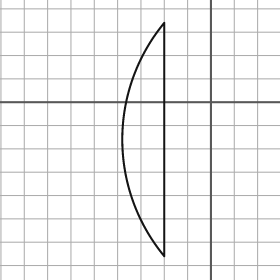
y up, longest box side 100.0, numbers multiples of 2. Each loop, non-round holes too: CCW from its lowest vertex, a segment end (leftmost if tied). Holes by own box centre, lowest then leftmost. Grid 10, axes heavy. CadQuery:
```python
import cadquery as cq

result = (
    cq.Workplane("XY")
    .moveTo(-20.0, -66.0)
    .lineTo(-20.0, 34.0)
    .threePointArc((-38.0, -16.0), (-20.0, -66.0))
    .close()
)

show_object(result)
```